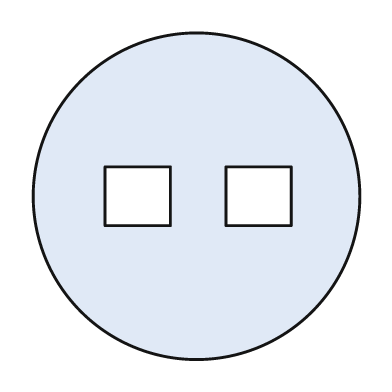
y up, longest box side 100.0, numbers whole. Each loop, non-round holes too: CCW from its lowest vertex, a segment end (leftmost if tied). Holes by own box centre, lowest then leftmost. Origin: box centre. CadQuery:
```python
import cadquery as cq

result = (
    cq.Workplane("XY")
    .moveTo(0.0, 0.0)
    .circle(50.0)
    .moveTo(-28.0, -9.0)
    .lineTo(-8.0, -9.0)
    .lineTo(-8.0, 9.0)
    .lineTo(-28.0, 9.0)
    .close()
    .moveTo(9.0, -9.0)
    .lineTo(29.0, -9.0)
    .lineTo(29.0, 9.0)
    .lineTo(9.0, 9.0)
    .close()
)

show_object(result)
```